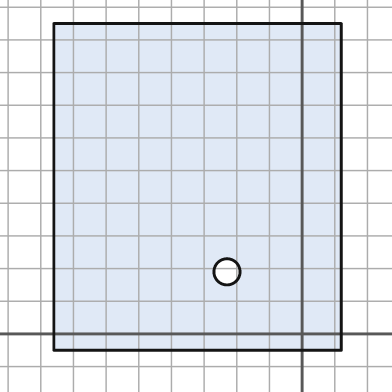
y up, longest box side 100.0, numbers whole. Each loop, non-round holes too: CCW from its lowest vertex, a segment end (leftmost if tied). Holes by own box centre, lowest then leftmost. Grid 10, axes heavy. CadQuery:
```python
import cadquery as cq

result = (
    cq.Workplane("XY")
    .moveTo(-76.0, -5.0)
    .lineTo(12.0, -5.0)
    .lineTo(12.0, 95.0)
    .lineTo(-76.0, 95.0)
    .close()
    .moveTo(-23.0, 19.0)
    .circle(4.0)
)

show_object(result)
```